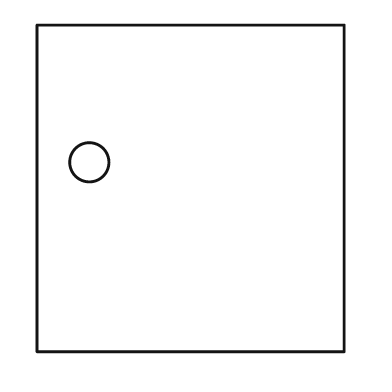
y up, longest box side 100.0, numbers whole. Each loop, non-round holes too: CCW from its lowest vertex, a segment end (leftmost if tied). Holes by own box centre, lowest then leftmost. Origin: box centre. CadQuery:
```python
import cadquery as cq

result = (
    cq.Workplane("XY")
    .moveTo(-47.0, -50.0)
    .lineTo(47.0, -50.0)
    .lineTo(47.0, 50.0)
    .lineTo(-47.0, 50.0)
    .close()
    .moveTo(-31.0, 8.0)
    .circle(6.0)
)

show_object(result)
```